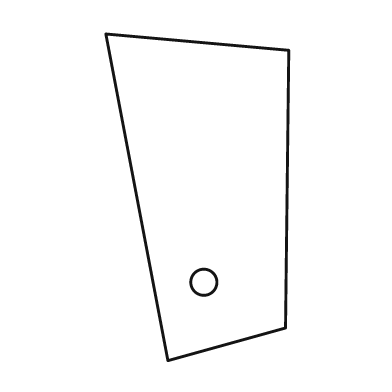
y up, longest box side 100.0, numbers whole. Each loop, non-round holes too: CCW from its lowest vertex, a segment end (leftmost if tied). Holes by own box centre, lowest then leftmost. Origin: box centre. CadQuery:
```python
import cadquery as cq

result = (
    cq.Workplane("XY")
    .moveTo(-9.0, -50.0)
    .lineTo(27.0, -40.0)
    .lineTo(28.0, 45.0)
    .lineTo(-28.0, 50.0)
    .close()
    .moveTo(2.0, -26.0)
    .circle(4.0)
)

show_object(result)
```